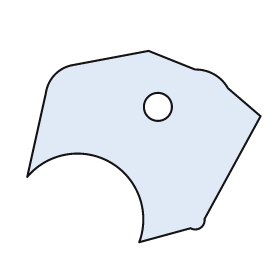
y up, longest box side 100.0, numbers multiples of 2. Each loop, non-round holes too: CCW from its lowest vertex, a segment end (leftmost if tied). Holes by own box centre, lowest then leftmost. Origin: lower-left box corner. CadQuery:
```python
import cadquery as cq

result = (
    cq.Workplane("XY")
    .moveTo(48.0, 0.0)
    .lineTo(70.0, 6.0)
    .threePointArc((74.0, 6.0), (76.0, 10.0))
    .lineTo(100.0, 54.0)
    .lineTo(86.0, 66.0)
    .threePointArc((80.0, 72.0), (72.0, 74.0))
    .lineTo(52.0, 82.0)
    .lineTo(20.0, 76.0)
    .threePointArc((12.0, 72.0), (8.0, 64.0))
    .lineTo(0.0, 28.0)
    .threePointArc((36.0, 34.0), (48.0, 0.0))
    .close()
    .moveTo(56.0, 58.0)
    .circle(6.0)
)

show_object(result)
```